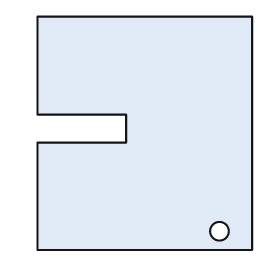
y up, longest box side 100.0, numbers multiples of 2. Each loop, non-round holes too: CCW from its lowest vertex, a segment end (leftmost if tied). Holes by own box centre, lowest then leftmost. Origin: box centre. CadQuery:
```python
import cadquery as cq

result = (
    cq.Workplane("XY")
    .moveTo(-46.0, -50.0)
    .lineTo(46.0, -50.0)
    .lineTo(46.0, 50.0)
    .lineTo(-46.0, 50.0)
    .lineTo(-46.0, 8.0)
    .lineTo(-8.0, 8.0)
    .lineTo(-8.0, -4.0)
    .lineTo(-46.0, -4.0)
    .close()
    .moveTo(32.0, -42.0)
    .circle(4.0)
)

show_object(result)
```